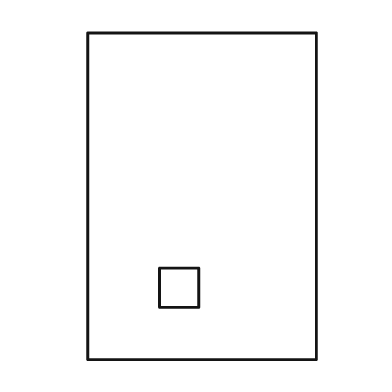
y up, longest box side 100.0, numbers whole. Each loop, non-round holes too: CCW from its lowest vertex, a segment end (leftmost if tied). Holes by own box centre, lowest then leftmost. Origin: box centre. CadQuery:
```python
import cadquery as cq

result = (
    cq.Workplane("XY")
    .moveTo(-35.0, -50.0)
    .lineTo(35.0, -50.0)
    .lineTo(35.0, 50.0)
    .lineTo(-35.0, 50.0)
    .close()
    .moveTo(-13.0, -34.0)
    .lineTo(-1.0, -34.0)
    .lineTo(-1.0, -22.0)
    .lineTo(-13.0, -22.0)
    .close()
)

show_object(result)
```